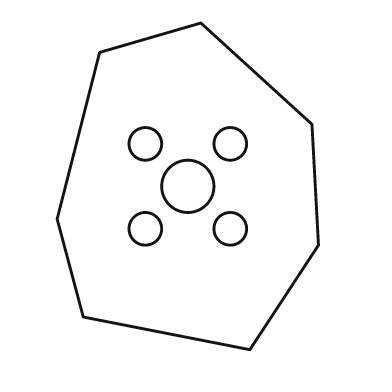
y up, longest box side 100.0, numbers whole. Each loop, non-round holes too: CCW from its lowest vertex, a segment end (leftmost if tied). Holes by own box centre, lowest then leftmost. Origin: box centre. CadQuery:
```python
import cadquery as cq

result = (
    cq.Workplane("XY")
    .moveTo(19.0, -50.0)
    .lineTo(40.0, -18.0)
    .lineTo(38.0, 19.0)
    .lineTo(4.0, 50.0)
    .lineTo(-27.0, 41.0)
    .lineTo(-40.0, -10.0)
    .lineTo(-32.0, -40.0)
    .close()
    .moveTo(-13.0, -13.0)
    .circle(5.0)
    .moveTo(13.0, -13.0)
    .circle(5.0)
    .moveTo(0.0, 0.0)
    .circle(8.0)
    .moveTo(-13.0, 13.0)
    .circle(5.0)
    .moveTo(13.0, 13.0)
    .circle(5.0)
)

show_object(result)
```